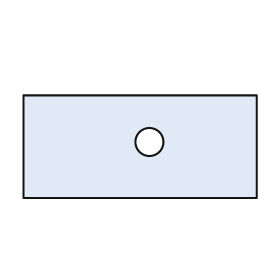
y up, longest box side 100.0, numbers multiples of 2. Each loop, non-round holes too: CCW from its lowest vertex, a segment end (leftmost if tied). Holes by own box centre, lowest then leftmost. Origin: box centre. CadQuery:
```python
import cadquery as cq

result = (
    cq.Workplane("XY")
    .moveTo(-50.0, -22.0)
    .lineTo(50.0, -22.0)
    .lineTo(50.0, 22.0)
    .lineTo(-50.0, 22.0)
    .close()
    .moveTo(4.0, 2.0)
    .circle(6.0)
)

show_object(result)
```